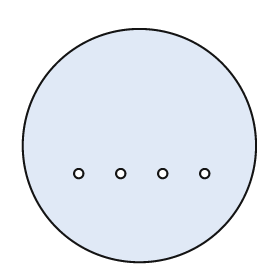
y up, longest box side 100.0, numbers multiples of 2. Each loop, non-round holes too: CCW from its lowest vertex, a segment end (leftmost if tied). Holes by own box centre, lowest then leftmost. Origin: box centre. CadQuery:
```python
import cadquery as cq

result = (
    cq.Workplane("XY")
    .moveTo(0.0, 0.0)
    .circle(50.0)
    .moveTo(-26.0, -12.0)
    .circle(2.0)
    .moveTo(-8.0, -12.0)
    .circle(2.0)
    .moveTo(10.0, -12.0)
    .circle(2.0)
    .moveTo(28.0, -12.0)
    .circle(2.0)
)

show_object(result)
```